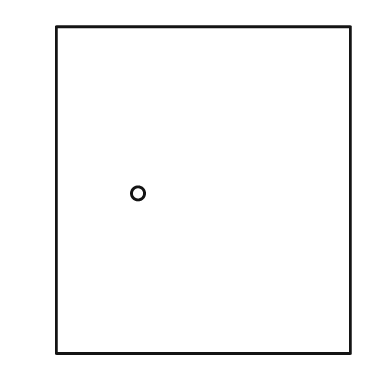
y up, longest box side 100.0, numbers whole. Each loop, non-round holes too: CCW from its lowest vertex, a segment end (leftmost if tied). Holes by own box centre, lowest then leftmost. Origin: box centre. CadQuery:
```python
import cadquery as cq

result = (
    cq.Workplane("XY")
    .moveTo(-45.0, -50.0)
    .lineTo(45.0, -50.0)
    .lineTo(45.0, 50.0)
    .lineTo(-45.0, 50.0)
    .close()
    .moveTo(-20.0, -1.0)
    .circle(2.0)
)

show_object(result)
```